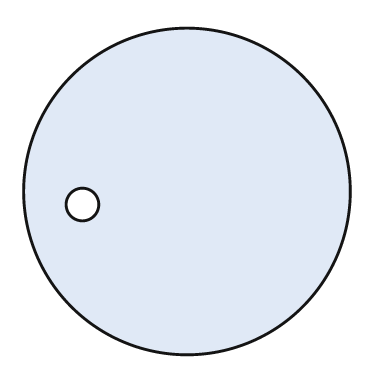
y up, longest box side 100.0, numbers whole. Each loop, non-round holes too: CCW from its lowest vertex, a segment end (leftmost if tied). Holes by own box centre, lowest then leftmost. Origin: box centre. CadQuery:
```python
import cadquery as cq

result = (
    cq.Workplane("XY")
    .moveTo(0.0, 0.0)
    .circle(50.0)
    .moveTo(-32.0, -4.0)
    .circle(5.0)
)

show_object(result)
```